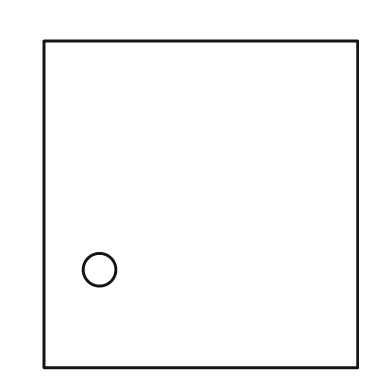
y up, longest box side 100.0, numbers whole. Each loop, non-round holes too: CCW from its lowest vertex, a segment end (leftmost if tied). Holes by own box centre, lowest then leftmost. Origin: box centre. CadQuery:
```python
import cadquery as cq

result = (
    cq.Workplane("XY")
    .moveTo(-48.0, -50.0)
    .lineTo(48.0, -50.0)
    .lineTo(48.0, 50.0)
    .lineTo(-48.0, 50.0)
    .close()
    .moveTo(-31.0, -20.0)
    .circle(5.0)
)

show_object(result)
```